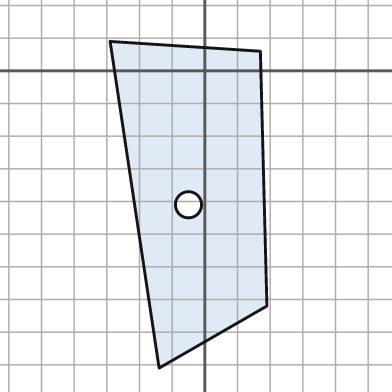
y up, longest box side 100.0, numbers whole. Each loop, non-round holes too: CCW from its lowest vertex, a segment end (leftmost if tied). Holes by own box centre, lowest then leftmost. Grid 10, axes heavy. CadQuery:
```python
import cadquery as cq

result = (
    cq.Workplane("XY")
    .moveTo(-14.0, -91.0)
    .lineTo(19.0, -72.0)
    .lineTo(17.0, 6.0)
    .lineTo(-29.0, 9.0)
    .close()
    .moveTo(-5.0, -41.0)
    .circle(4.0)
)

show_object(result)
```